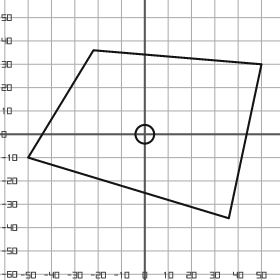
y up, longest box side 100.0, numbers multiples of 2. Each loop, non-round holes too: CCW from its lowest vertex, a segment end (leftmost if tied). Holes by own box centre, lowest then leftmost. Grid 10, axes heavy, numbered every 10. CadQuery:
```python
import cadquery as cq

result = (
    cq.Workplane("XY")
    .moveTo(36.0, -36.0)
    .lineTo(50.0, 30.0)
    .lineTo(-22.0, 36.0)
    .lineTo(-50.0, -10.0)
    .close()
    .moveTo(0.0, 0.0)
    .circle(4.0)
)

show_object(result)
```